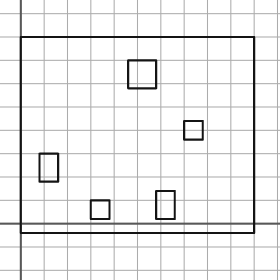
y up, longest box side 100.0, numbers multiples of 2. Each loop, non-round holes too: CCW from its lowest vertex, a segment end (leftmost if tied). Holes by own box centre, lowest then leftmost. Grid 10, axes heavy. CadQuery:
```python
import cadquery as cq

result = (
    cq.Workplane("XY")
    .moveTo(0.0, -4.0)
    .lineTo(100.0, -4.0)
    .lineTo(100.0, 80.0)
    .lineTo(0.0, 80.0)
    .close()
    .moveTo(30.0, 2.0)
    .lineTo(38.0, 2.0)
    .lineTo(38.0, 10.0)
    .lineTo(30.0, 10.0)
    .close()
    .moveTo(58.0, 2.0)
    .lineTo(66.0, 2.0)
    .lineTo(66.0, 14.0)
    .lineTo(58.0, 14.0)
    .close()
    .moveTo(8.0, 18.0)
    .lineTo(16.0, 18.0)
    .lineTo(16.0, 30.0)
    .lineTo(8.0, 30.0)
    .close()
    .moveTo(70.0, 36.0)
    .lineTo(78.0, 36.0)
    .lineTo(78.0, 44.0)
    .lineTo(70.0, 44.0)
    .close()
    .moveTo(46.0, 58.0)
    .lineTo(58.0, 58.0)
    .lineTo(58.0, 70.0)
    .lineTo(46.0, 70.0)
    .close()
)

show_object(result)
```